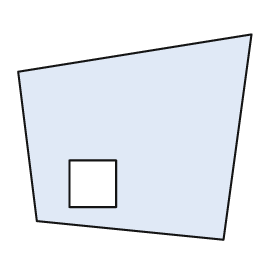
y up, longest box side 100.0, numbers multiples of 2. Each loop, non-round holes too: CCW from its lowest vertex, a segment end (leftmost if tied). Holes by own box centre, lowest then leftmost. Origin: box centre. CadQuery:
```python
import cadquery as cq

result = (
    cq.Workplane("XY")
    .moveTo(38.0, -44.0)
    .lineTo(50.0, 44.0)
    .lineTo(-50.0, 28.0)
    .lineTo(-42.0, -36.0)
    .close()
    .moveTo(-28.0, -30.0)
    .lineTo(-8.0, -30.0)
    .lineTo(-8.0, -10.0)
    .lineTo(-28.0, -10.0)
    .close()
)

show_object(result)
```